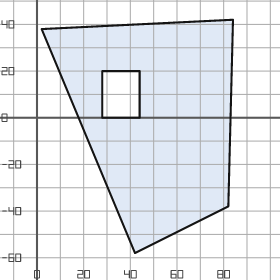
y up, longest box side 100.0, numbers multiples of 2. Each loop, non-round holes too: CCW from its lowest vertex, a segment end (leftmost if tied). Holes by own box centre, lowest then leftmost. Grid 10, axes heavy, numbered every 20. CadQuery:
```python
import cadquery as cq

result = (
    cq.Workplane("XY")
    .moveTo(42.0, -58.0)
    .lineTo(82.0, -38.0)
    .lineTo(84.0, 42.0)
    .lineTo(2.0, 38.0)
    .close()
    .moveTo(28.0, 0.0)
    .lineTo(44.0, 0.0)
    .lineTo(44.0, 20.0)
    .lineTo(28.0, 20.0)
    .close()
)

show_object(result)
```